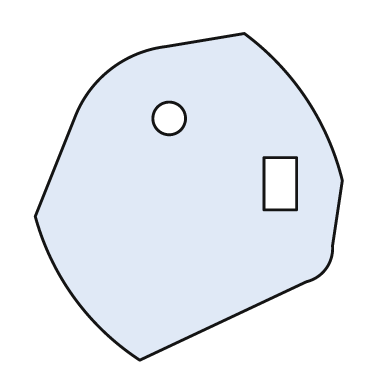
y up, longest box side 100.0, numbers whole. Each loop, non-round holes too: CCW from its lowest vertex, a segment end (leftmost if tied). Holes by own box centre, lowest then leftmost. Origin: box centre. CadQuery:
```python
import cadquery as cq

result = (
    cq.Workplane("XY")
    .moveTo(-15.0, -50.0)
    .lineTo(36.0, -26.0)
    .threePointArc((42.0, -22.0), (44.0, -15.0))
    .lineTo(47.0, 5.0)
    .threePointArc((36.0, 30.0), (17.0, 50.0))
    .lineTo(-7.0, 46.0)
    .threePointArc((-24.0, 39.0), (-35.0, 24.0))
    .lineTo(-47.0, -6.0)
    .threePointArc((-35.0, -31.0), (-15.0, -50.0))
    .close()
    .moveTo(23.0, -4.0)
    .lineTo(33.0, -4.0)
    .lineTo(33.0, 12.0)
    .lineTo(23.0, 12.0)
    .close()
    .moveTo(-6.0, 24.0)
    .circle(5.0)
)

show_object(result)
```